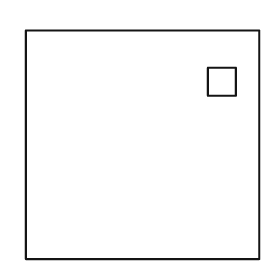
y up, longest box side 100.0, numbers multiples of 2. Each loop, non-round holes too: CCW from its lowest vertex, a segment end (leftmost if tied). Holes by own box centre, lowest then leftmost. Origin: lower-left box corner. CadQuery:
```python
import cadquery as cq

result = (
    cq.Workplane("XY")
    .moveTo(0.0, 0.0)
    .lineTo(100.0, 0.0)
    .lineTo(100.0, 98.0)
    .lineTo(0.0, 98.0)
    .close()
    .moveTo(78.0, 70.0)
    .lineTo(90.0, 70.0)
    .lineTo(90.0, 82.0)
    .lineTo(78.0, 82.0)
    .close()
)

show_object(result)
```